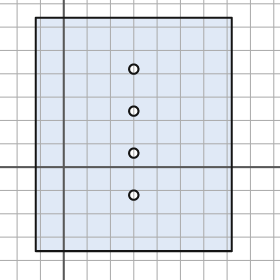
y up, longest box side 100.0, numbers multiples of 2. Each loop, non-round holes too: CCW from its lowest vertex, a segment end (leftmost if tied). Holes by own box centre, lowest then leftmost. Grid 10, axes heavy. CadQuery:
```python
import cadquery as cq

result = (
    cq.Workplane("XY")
    .moveTo(-12.0, -36.0)
    .lineTo(72.0, -36.0)
    .lineTo(72.0, 64.0)
    .lineTo(-12.0, 64.0)
    .close()
    .moveTo(30.0, -12.0)
    .circle(2.0)
    .moveTo(30.0, 6.0)
    .circle(2.0)
    .moveTo(30.0, 24.0)
    .circle(2.0)
    .moveTo(30.0, 42.0)
    .circle(2.0)
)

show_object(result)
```